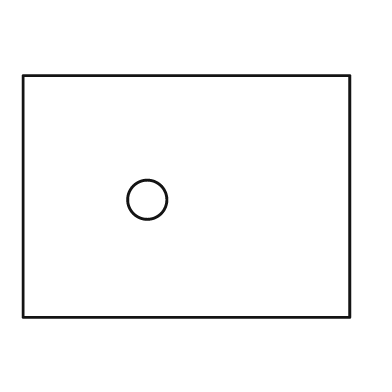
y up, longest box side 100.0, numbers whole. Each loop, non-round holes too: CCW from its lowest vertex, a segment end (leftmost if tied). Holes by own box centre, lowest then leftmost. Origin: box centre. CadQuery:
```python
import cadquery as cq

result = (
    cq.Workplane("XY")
    .moveTo(-50.0, -37.0)
    .lineTo(50.0, -37.0)
    .lineTo(50.0, 37.0)
    .lineTo(-50.0, 37.0)
    .close()
    .moveTo(-12.0, -1.0)
    .circle(6.0)
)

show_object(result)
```